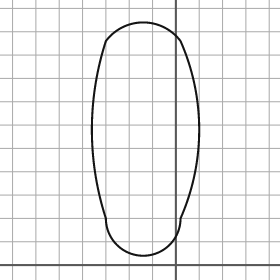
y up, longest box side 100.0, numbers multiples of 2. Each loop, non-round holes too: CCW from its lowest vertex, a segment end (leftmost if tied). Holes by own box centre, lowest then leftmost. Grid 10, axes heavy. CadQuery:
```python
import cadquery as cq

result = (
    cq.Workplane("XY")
    .moveTo(-30.0, 20.0)
    .threePointArc((-14.0, 4.0), (2.0, 20.0))
    .threePointArc((10.0, 58.0), (2.0, 96.0))
    .threePointArc((-14.0, 104.0), (-30.0, 96.0))
    .threePointArc((-36.0, 58.0), (-30.0, 20.0))
    .close()
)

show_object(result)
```